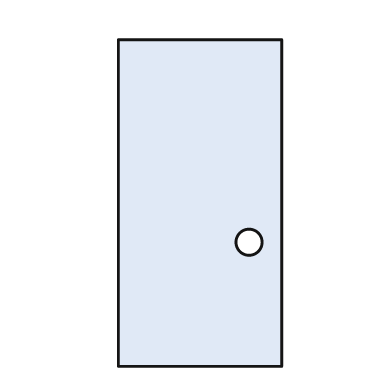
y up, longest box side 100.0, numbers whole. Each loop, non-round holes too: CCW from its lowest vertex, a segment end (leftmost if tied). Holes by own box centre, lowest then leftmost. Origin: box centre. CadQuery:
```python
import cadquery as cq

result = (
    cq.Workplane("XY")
    .moveTo(-25.0, -50.0)
    .lineTo(25.0, -50.0)
    .lineTo(25.0, 50.0)
    .lineTo(-25.0, 50.0)
    .close()
    .moveTo(15.0, -12.0)
    .circle(4.0)
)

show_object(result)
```